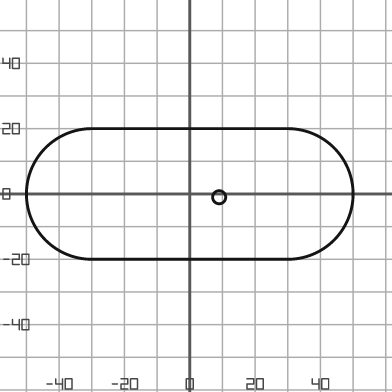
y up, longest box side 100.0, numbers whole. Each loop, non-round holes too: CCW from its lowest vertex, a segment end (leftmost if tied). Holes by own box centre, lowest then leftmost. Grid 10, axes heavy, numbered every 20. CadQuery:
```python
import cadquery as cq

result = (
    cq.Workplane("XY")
    .moveTo(-30.0, -20.0)
    .lineTo(30.0, -20.0)
    .threePointArc((50.0, 0.0), (30.0, 20.0))
    .lineTo(-30.0, 20.0)
    .threePointArc((-50.0, 0.0), (-30.0, -20.0))
    .close()
    .moveTo(9.0, -1.0)
    .circle(2.0)
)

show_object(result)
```